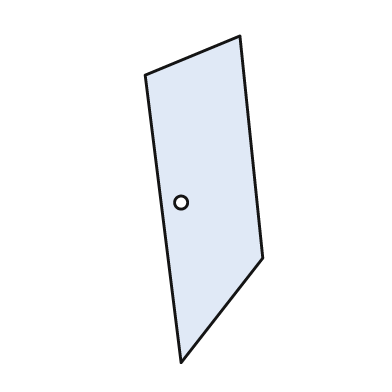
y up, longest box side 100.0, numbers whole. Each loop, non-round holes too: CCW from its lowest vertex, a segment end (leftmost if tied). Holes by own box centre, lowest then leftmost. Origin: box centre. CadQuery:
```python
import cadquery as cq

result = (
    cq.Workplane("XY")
    .moveTo(-7.0, -50.0)
    .lineTo(18.0, -18.0)
    .lineTo(11.0, 50.0)
    .lineTo(-18.0, 38.0)
    .close()
    .moveTo(-7.0, -1.0)
    .circle(2.0)
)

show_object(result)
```